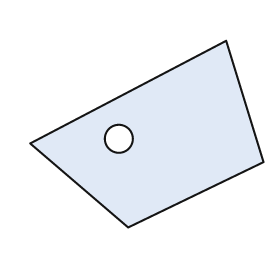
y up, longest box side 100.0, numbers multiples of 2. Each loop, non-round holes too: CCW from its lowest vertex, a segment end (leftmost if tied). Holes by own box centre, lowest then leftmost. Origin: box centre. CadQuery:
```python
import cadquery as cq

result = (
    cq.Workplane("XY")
    .moveTo(-8.0, -40.0)
    .lineTo(50.0, -12.0)
    .lineTo(34.0, 40.0)
    .lineTo(-50.0, -4.0)
    .close()
    .moveTo(-12.0, -2.0)
    .circle(6.0)
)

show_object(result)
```